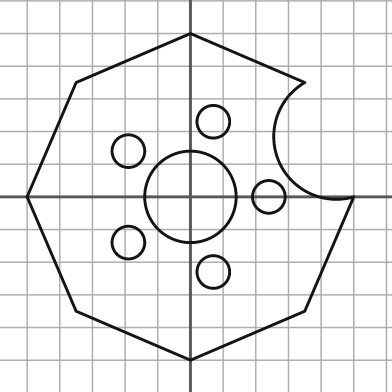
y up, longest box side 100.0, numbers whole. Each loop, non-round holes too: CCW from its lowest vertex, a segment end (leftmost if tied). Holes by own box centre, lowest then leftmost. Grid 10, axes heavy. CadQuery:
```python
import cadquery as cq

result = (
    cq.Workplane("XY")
    .moveTo(0.0, -50.0)
    .lineTo(35.0, -35.0)
    .lineTo(50.0, 0.0)
    .threePointArc((27.0, 11.0), (35.0, 35.0))
    .lineTo(0.0, 50.0)
    .lineTo(-35.0, 35.0)
    .lineTo(-50.0, 0.0)
    .lineTo(-35.0, -35.0)
    .close()
    .moveTo(7.0, -23.0)
    .circle(5.0)
    .moveTo(-19.0, -14.0)
    .circle(5.0)
    .moveTo(0.0, 0.0)
    .circle(14.0)
    .moveTo(24.0, 0.0)
    .circle(5.0)
    .moveTo(-19.0, 14.0)
    .circle(5.0)
    .moveTo(7.0, 23.0)
    .circle(5.0)
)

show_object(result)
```